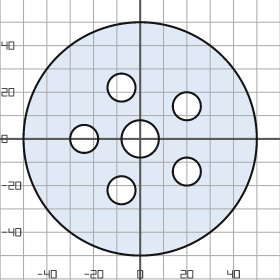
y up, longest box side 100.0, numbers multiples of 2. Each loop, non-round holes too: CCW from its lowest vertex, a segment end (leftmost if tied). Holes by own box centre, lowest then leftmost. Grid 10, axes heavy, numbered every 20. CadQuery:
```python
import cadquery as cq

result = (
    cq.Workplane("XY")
    .moveTo(0.0, 0.0)
    .circle(50.0)
    .moveTo(-8.0, -22.0)
    .circle(6.0)
    .moveTo(20.0, -14.0)
    .circle(6.0)
    .moveTo(-24.0, 0.0)
    .circle(6.0)
    .moveTo(0.0, 0.0)
    .circle(8.0)
    .moveTo(20.0, 14.0)
    .circle(6.0)
    .moveTo(-8.0, 22.0)
    .circle(6.0)
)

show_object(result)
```